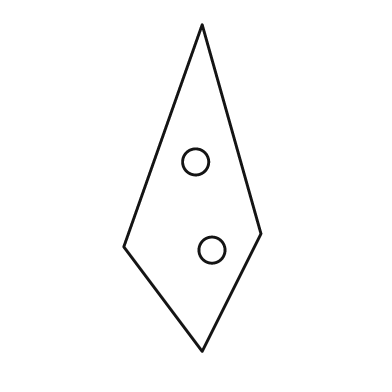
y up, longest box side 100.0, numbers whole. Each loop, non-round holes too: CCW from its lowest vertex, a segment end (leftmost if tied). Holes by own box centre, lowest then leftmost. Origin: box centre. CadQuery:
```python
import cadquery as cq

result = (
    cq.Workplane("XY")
    .moveTo(3.0, -50.0)
    .lineTo(21.0, -14.0)
    .lineTo(3.0, 50.0)
    .lineTo(-21.0, -18.0)
    .close()
    .moveTo(6.0, -19.0)
    .circle(4.0)
    .moveTo(1.0, 8.0)
    .circle(4.0)
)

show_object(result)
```